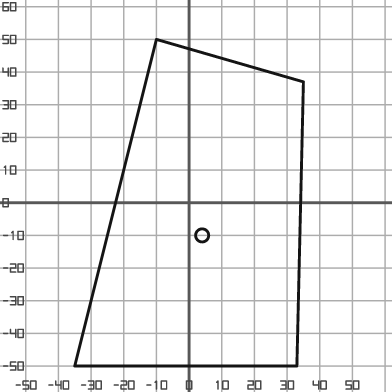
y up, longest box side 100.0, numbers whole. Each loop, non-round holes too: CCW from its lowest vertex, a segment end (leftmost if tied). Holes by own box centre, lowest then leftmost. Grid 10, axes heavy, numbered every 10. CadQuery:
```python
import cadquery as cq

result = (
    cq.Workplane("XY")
    .moveTo(-35.0, -50.0)
    .lineTo(33.0, -50.0)
    .lineTo(35.0, 37.0)
    .lineTo(-10.0, 50.0)
    .close()
    .moveTo(4.0, -10.0)
    .circle(2.0)
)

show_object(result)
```